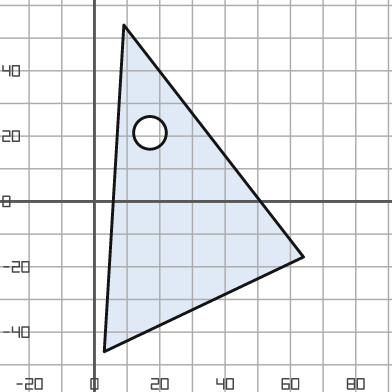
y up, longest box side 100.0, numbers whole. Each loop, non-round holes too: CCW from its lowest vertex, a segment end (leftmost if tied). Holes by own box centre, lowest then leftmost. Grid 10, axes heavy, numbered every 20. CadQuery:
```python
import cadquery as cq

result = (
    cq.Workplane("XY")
    .moveTo(3.0, -46.0)
    .lineTo(64.0, -17.0)
    .lineTo(9.0, 54.0)
    .close()
    .moveTo(17.0, 21.0)
    .circle(5.0)
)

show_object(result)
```